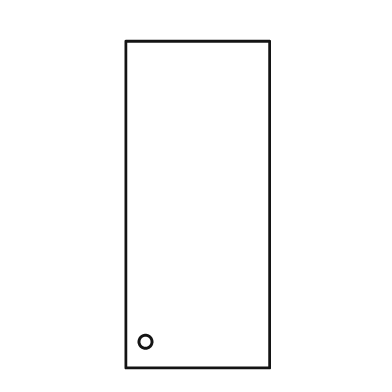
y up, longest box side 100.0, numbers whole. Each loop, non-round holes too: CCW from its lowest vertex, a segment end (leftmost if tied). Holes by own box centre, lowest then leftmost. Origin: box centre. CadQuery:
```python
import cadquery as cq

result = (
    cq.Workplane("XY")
    .moveTo(-22.0, -50.0)
    .lineTo(22.0, -50.0)
    .lineTo(22.0, 50.0)
    .lineTo(-22.0, 50.0)
    .close()
    .moveTo(-16.0, -42.0)
    .circle(2.0)
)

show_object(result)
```